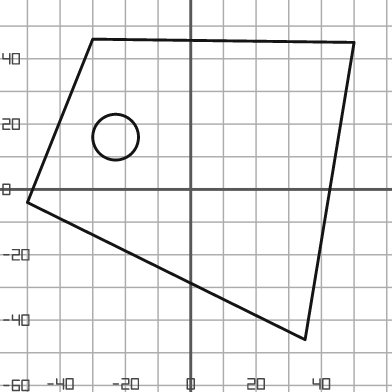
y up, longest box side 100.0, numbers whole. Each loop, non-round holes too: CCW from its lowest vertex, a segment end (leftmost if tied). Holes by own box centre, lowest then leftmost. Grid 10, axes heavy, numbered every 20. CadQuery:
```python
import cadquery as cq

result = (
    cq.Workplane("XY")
    .moveTo(35.0, -46.0)
    .lineTo(50.0, 45.0)
    .lineTo(-30.0, 46.0)
    .lineTo(-50.0, -4.0)
    .close()
    .moveTo(-23.0, 16.0)
    .circle(7.0)
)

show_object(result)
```